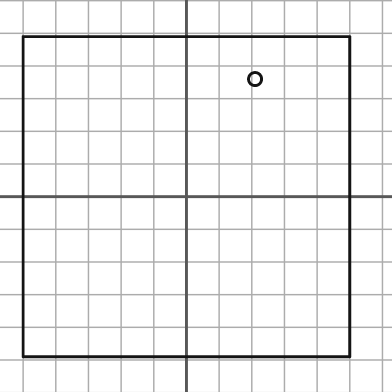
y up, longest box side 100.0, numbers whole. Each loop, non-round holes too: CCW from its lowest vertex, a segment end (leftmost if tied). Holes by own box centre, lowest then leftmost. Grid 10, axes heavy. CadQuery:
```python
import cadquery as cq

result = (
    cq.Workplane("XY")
    .moveTo(-50.0, -49.0)
    .lineTo(50.0, -49.0)
    .lineTo(50.0, 49.0)
    .lineTo(-50.0, 49.0)
    .close()
    .moveTo(21.0, 36.0)
    .circle(2.0)
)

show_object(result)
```